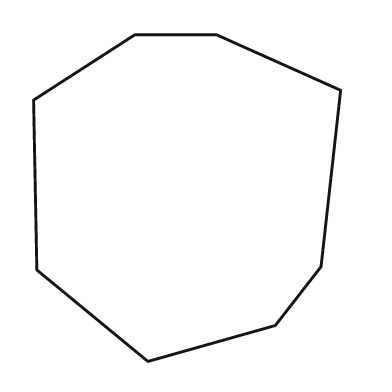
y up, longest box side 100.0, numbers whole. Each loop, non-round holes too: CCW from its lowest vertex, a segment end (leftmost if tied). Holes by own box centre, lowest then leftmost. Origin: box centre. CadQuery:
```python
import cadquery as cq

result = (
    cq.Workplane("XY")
    .moveTo(-12.0, -50.0)
    .lineTo(27.0, -39.0)
    .lineTo(41.0, -21.0)
    .lineTo(47.0, 33.0)
    .lineTo(9.0, 50.0)
    .lineTo(-16.0, 50.0)
    .lineTo(-47.0, 30.0)
    .lineTo(-46.0, -22.0)
    .close()
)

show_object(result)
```